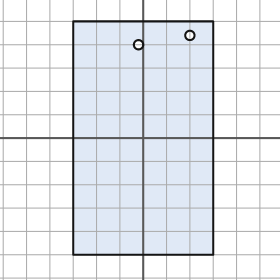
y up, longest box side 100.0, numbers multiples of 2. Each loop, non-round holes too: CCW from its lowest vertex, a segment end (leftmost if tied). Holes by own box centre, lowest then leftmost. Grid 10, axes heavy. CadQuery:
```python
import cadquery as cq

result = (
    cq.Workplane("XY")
    .moveTo(-30.0, -50.0)
    .lineTo(30.0, -50.0)
    .lineTo(30.0, 50.0)
    .lineTo(-30.0, 50.0)
    .close()
    .moveTo(-2.0, 40.0)
    .circle(2.0)
    .moveTo(20.0, 44.0)
    .circle(2.0)
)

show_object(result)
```